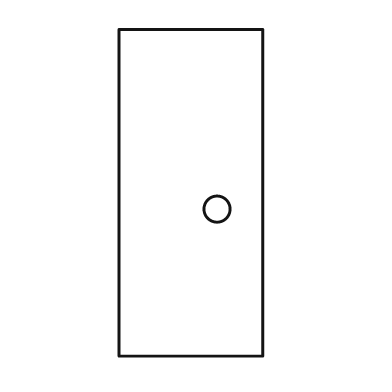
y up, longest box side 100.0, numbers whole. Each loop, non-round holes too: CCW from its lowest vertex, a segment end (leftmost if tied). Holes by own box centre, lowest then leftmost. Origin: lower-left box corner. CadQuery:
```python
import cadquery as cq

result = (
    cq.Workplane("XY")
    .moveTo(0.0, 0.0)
    .lineTo(44.0, 0.0)
    .lineTo(44.0, 100.0)
    .lineTo(0.0, 100.0)
    .close()
    .moveTo(30.0, 45.0)
    .circle(4.0)
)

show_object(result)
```